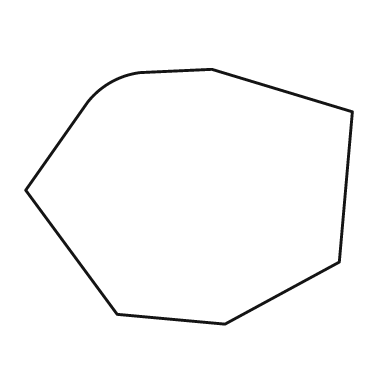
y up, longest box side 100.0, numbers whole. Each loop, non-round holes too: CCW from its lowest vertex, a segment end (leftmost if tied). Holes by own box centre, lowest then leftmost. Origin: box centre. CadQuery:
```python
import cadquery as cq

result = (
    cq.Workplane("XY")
    .moveTo(11.0, -39.0)
    .lineTo(46.0, -20.0)
    .lineTo(50.0, 26.0)
    .lineTo(7.0, 39.0)
    .lineTo(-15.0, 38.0)
    .threePointArc((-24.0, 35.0), (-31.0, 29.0))
    .lineTo(-50.0, 2.0)
    .lineTo(-22.0, -36.0)
    .close()
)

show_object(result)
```